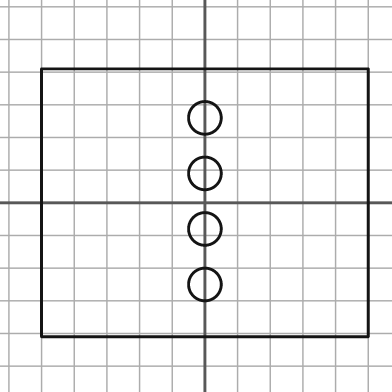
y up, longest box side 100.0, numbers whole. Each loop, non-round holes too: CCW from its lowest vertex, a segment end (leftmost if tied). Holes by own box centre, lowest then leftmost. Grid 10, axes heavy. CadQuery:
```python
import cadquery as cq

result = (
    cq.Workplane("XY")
    .moveTo(-50.0, -41.0)
    .lineTo(50.0, -41.0)
    .lineTo(50.0, 41.0)
    .lineTo(-50.0, 41.0)
    .close()
    .moveTo(0.0, -25.0)
    .circle(5.0)
    .moveTo(0.0, -8.0)
    .circle(5.0)
    .moveTo(0.0, 9.0)
    .circle(5.0)
    .moveTo(0.0, 26.0)
    .circle(5.0)
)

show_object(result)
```